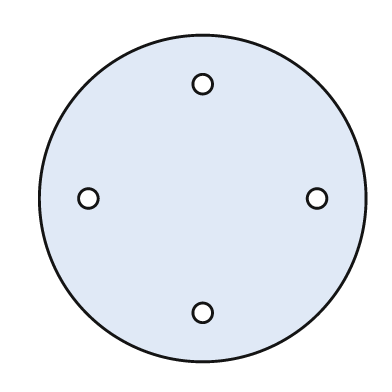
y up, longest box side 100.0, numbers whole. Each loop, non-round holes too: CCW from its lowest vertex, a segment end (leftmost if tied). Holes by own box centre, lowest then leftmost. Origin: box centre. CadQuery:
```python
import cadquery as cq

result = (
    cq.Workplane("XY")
    .moveTo(0.0, 0.0)
    .circle(50.0)
    .moveTo(0.0, -35.0)
    .circle(3.0)
    .moveTo(-35.0, 0.0)
    .circle(3.0)
    .moveTo(35.0, 0.0)
    .circle(3.0)
    .moveTo(0.0, 35.0)
    .circle(3.0)
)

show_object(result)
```